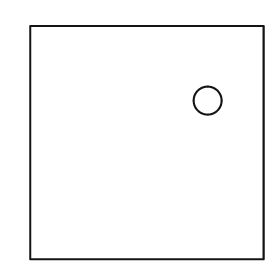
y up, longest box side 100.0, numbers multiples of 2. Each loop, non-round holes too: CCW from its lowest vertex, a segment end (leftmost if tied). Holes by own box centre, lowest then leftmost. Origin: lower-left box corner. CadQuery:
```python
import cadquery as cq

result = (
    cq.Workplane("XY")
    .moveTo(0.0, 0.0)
    .lineTo(100.0, 0.0)
    .lineTo(100.0, 100.0)
    .lineTo(0.0, 100.0)
    .close()
    .moveTo(76.0, 68.0)
    .circle(6.0)
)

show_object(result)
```